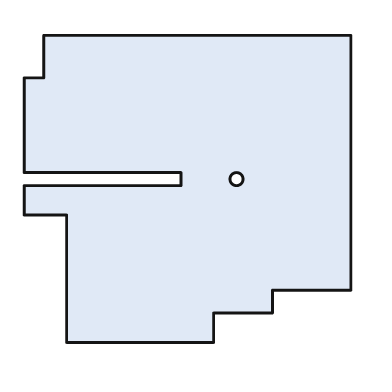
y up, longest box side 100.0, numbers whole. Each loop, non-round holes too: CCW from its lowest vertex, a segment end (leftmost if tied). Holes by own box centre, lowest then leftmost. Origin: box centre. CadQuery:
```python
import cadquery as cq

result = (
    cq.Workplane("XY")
    .moveTo(-37.0, -47.0)
    .lineTo(8.0, -47.0)
    .lineTo(8.0, -38.0)
    .lineTo(26.0, -38.0)
    .lineTo(26.0, -31.0)
    .lineTo(50.0, -31.0)
    .lineTo(50.0, 47.0)
    .lineTo(-44.0, 47.0)
    .lineTo(-44.0, 34.0)
    .lineTo(-50.0, 34.0)
    .lineTo(-50.0, 5.0)
    .lineTo(-2.0, 5.0)
    .lineTo(-2.0, 1.0)
    .lineTo(-50.0, 1.0)
    .lineTo(-50.0, -8.0)
    .lineTo(-37.0, -8.0)
    .close()
    .moveTo(15.0, 3.0)
    .circle(2.0)
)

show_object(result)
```